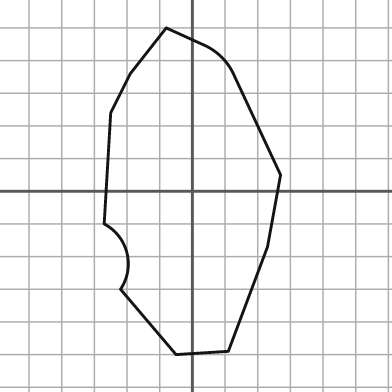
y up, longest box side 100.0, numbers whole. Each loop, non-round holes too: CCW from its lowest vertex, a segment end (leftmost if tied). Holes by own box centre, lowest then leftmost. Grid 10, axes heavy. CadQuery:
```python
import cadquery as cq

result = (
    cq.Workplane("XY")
    .moveTo(-5.0, -50.0)
    .lineTo(11.0, -49.0)
    .lineTo(23.0, -17.0)
    .lineTo(27.0, 5.0)
    .lineTo(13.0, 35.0)
    .threePointArc((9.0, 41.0), (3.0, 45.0))
    .lineTo(-8.0, 50.0)
    .lineTo(-19.0, 36.0)
    .lineTo(-25.0, 24.0)
    .lineTo(-27.0, -10.0)
    .threePointArc((-20.0, -19.0), (-22.0, -30.0))
    .close()
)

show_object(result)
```